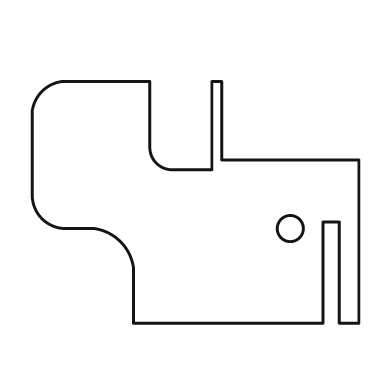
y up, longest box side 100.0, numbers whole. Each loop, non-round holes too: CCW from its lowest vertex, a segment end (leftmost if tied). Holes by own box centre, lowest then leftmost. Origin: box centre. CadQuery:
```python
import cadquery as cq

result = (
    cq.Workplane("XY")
    .moveTo(-19.0, -37.0)
    .lineTo(39.0, -37.0)
    .lineTo(39.0, -6.0)
    .lineTo(44.0, -6.0)
    .lineTo(44.0, -37.0)
    .lineTo(50.0, -37.0)
    .lineTo(50.0, 13.0)
    .lineTo(8.0, 13.0)
    .lineTo(8.0, 37.0)
    .lineTo(5.0, 37.0)
    .lineTo(5.0, 10.0)
    .lineTo(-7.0, 10.0)
    .threePointArc((-12.0, 12.0), (-14.0, 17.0))
    .lineTo(-14.0, 37.0)
    .lineTo(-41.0, 37.0)
    .threePointArc((-47.0, 34.0), (-50.0, 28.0))
    .lineTo(-50.0, 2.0)
    .threePointArc((-47.0, -5.0), (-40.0, -8.0))
    .lineTo(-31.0, -8.0)
    .threePointArc((-23.0, -12.0), (-19.0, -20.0))
    .close()
    .moveTo(29.0, -8.0)
    .circle(4.0)
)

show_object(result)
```